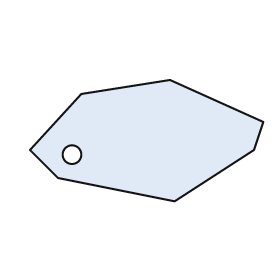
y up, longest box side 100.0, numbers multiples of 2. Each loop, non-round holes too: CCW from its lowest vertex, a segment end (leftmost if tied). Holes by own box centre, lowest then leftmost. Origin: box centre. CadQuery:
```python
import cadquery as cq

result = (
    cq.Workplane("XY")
    .moveTo(12.0, -26.0)
    .lineTo(46.0, -4.0)
    .lineTo(50.0, 8.0)
    .lineTo(10.0, 26.0)
    .lineTo(-28.0, 20.0)
    .lineTo(-50.0, -4.0)
    .lineTo(-38.0, -16.0)
    .close()
    .moveTo(-32.0, -6.0)
    .circle(4.0)
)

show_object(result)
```